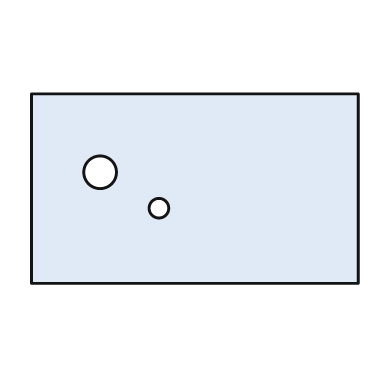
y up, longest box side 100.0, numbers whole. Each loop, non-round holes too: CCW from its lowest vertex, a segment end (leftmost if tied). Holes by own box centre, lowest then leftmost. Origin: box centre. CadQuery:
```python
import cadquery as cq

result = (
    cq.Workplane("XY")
    .moveTo(-50.0, -29.0)
    .lineTo(50.0, -29.0)
    .lineTo(50.0, 29.0)
    .lineTo(-50.0, 29.0)
    .close()
    .moveTo(-11.0, -6.0)
    .circle(3.0)
    .moveTo(-29.0, 5.0)
    .circle(5.0)
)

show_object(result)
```